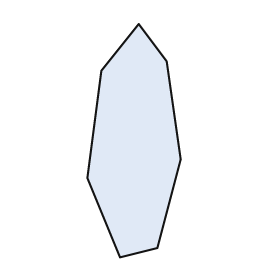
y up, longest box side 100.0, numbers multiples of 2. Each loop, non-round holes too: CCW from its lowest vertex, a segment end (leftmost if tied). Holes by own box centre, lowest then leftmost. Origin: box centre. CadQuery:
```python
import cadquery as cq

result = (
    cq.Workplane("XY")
    .moveTo(-6.0, -50.0)
    .lineTo(10.0, -46.0)
    .lineTo(20.0, -8.0)
    .lineTo(14.0, 34.0)
    .lineTo(2.0, 50.0)
    .lineTo(-14.0, 30.0)
    .lineTo(-20.0, -16.0)
    .close()
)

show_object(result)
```